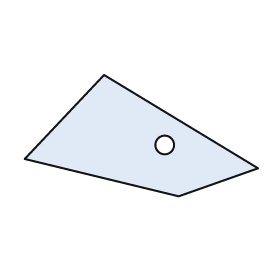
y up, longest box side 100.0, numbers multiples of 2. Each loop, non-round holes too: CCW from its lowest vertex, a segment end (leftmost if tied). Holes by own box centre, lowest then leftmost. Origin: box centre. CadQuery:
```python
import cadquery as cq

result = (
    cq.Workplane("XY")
    .moveTo(16.0, -26.0)
    .lineTo(50.0, -14.0)
    .lineTo(-16.0, 26.0)
    .lineTo(-50.0, -10.0)
    .close()
    .moveTo(10.0, -4.0)
    .circle(4.0)
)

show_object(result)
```